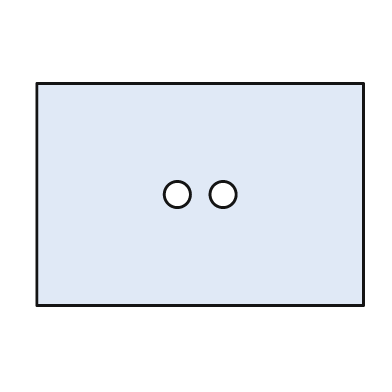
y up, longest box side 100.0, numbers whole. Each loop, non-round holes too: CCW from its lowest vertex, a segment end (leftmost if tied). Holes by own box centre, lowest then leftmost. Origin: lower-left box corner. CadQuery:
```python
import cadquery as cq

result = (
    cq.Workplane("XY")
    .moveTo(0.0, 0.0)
    .lineTo(100.0, 0.0)
    .lineTo(100.0, 68.0)
    .lineTo(0.0, 68.0)
    .close()
    .moveTo(43.0, 34.0)
    .circle(4.0)
    .moveTo(57.0, 34.0)
    .circle(4.0)
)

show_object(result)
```